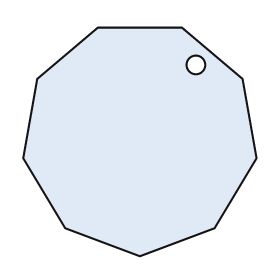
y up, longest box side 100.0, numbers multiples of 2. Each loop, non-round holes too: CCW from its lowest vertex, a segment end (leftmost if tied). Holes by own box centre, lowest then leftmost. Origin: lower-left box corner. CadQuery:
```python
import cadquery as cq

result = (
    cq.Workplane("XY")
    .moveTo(50.0, 0.0)
    .lineTo(82.0, 12.0)
    .lineTo(100.0, 42.0)
    .lineTo(94.0, 76.0)
    .lineTo(68.0, 98.0)
    .lineTo(32.0, 98.0)
    .lineTo(6.0, 76.0)
    .lineTo(0.0, 42.0)
    .lineTo(18.0, 12.0)
    .close()
    .moveTo(74.0, 82.0)
    .circle(4.0)
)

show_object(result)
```